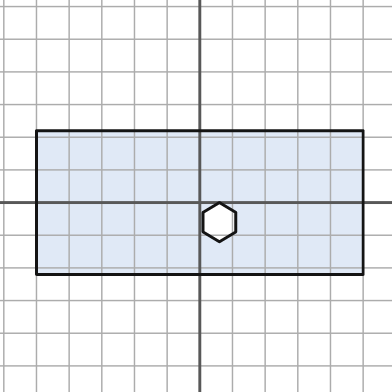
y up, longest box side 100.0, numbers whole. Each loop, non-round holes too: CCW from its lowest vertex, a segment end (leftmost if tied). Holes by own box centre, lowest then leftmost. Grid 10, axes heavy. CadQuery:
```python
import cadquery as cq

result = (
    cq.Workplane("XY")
    .moveTo(-50.0, -22.0)
    .lineTo(50.0, -22.0)
    .lineTo(50.0, 22.0)
    .lineTo(-50.0, 22.0)
    .close()
    .moveTo(6.0, -12.0)
    .lineTo(11.0, -9.0)
    .lineTo(11.0, -3.0)
    .lineTo(6.0, 0.0)
    .lineTo(1.0, -3.0)
    .lineTo(1.0, -9.0)
    .close()
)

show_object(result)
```